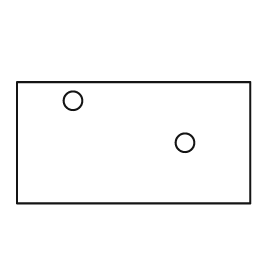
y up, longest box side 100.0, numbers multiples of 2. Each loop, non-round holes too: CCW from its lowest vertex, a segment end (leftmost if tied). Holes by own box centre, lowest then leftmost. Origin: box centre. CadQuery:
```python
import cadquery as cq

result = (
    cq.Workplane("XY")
    .moveTo(-50.0, -26.0)
    .lineTo(50.0, -26.0)
    .lineTo(50.0, 26.0)
    .lineTo(-50.0, 26.0)
    .close()
    .moveTo(22.0, 0.0)
    .circle(4.0)
    .moveTo(-26.0, 18.0)
    .circle(4.0)
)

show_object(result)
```